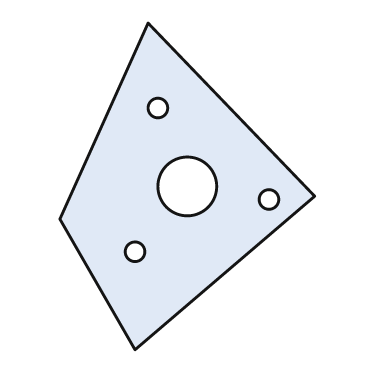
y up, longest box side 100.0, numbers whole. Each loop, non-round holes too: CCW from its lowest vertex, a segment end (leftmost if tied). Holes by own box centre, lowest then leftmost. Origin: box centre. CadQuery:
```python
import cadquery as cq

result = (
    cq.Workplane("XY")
    .moveTo(-16.0, -50.0)
    .lineTo(39.0, -3.0)
    .lineTo(-12.0, 50.0)
    .lineTo(-39.0, -10.0)
    .close()
    .moveTo(-16.0, -20.0)
    .circle(3.0)
    .moveTo(25.0, -4.0)
    .circle(3.0)
    .moveTo(0.0, 0.0)
    .circle(9.0)
    .moveTo(-9.0, 24.0)
    .circle(3.0)
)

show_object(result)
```